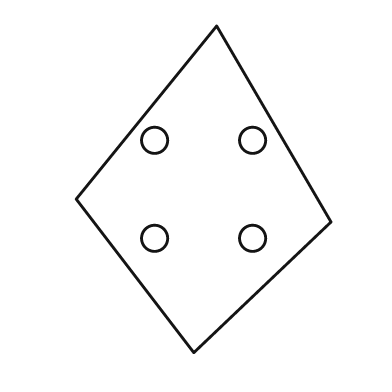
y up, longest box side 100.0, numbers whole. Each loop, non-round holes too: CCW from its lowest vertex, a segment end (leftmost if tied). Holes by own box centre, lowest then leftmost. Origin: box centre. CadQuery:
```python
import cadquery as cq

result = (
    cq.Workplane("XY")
    .moveTo(-3.0, -50.0)
    .lineTo(39.0, -10.0)
    .lineTo(4.0, 50.0)
    .lineTo(-39.0, -3.0)
    .close()
    .moveTo(-15.0, -15.0)
    .circle(4.0)
    .moveTo(15.0, -15.0)
    .circle(4.0)
    .moveTo(-15.0, 15.0)
    .circle(4.0)
    .moveTo(15.0, 15.0)
    .circle(4.0)
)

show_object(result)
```